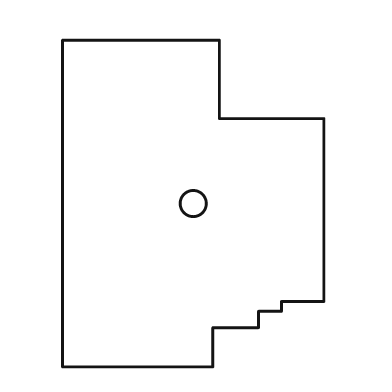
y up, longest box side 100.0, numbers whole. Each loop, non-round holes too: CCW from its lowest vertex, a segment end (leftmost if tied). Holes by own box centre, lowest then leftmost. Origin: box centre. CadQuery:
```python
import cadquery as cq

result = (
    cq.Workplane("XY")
    .moveTo(-40.0, -50.0)
    .lineTo(6.0, -50.0)
    .lineTo(6.0, -38.0)
    .lineTo(20.0, -38.0)
    .lineTo(20.0, -33.0)
    .lineTo(27.0, -33.0)
    .lineTo(27.0, -30.0)
    .lineTo(40.0, -30.0)
    .lineTo(40.0, 26.0)
    .lineTo(8.0, 26.0)
    .lineTo(8.0, 50.0)
    .lineTo(-40.0, 50.0)
    .close()
    .moveTo(0.0, 0.0)
    .circle(4.0)
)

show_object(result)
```